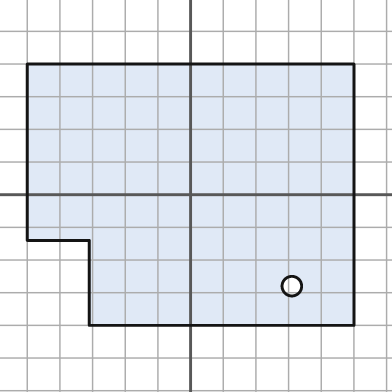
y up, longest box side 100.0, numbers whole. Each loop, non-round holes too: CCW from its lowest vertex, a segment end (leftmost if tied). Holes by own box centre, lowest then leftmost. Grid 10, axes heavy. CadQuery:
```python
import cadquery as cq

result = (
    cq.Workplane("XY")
    .moveTo(-31.0, -40.0)
    .lineTo(50.0, -40.0)
    .lineTo(50.0, 40.0)
    .lineTo(-50.0, 40.0)
    .lineTo(-50.0, -14.0)
    .lineTo(-31.0, -14.0)
    .close()
    .moveTo(31.0, -28.0)
    .circle(3.0)
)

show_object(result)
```